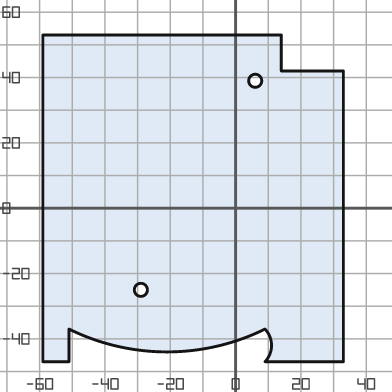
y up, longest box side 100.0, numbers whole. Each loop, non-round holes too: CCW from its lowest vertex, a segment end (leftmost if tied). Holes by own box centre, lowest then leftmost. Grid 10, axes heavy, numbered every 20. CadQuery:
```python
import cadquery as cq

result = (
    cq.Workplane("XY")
    .moveTo(-59.0, -47.0)
    .lineTo(-51.0, -47.0)
    .lineTo(-51.0, -37.0)
    .threePointArc((-21.0, -44.0), (9.0, -37.0))
    .threePointArc((11.0, -42.0), (9.0, -47.0))
    .lineTo(33.0, -47.0)
    .lineTo(33.0, 42.0)
    .lineTo(14.0, 42.0)
    .lineTo(14.0, 53.0)
    .lineTo(-59.0, 53.0)
    .close()
    .moveTo(-29.0, -25.0)
    .circle(2.0)
    .moveTo(6.0, 39.0)
    .circle(2.0)
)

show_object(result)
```